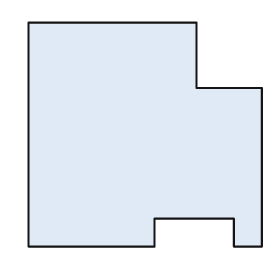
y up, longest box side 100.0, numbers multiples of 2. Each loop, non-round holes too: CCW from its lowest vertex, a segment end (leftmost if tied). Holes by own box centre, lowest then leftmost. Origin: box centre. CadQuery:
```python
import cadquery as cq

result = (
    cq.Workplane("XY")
    .moveTo(-50.0, -48.0)
    .lineTo(4.0, -48.0)
    .lineTo(4.0, -36.0)
    .lineTo(38.0, -36.0)
    .lineTo(38.0, -48.0)
    .lineTo(50.0, -48.0)
    .lineTo(50.0, 20.0)
    .lineTo(22.0, 20.0)
    .lineTo(22.0, 48.0)
    .lineTo(-50.0, 48.0)
    .close()
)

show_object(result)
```